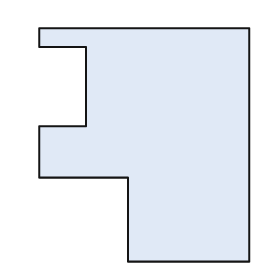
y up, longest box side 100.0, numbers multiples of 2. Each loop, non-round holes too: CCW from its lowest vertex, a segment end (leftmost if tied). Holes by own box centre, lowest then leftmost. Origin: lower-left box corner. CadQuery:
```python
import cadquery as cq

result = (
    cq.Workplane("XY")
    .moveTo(38.0, 0.0)
    .lineTo(90.0, 0.0)
    .lineTo(90.0, 100.0)
    .lineTo(0.0, 100.0)
    .lineTo(0.0, 92.0)
    .lineTo(20.0, 92.0)
    .lineTo(20.0, 58.0)
    .lineTo(0.0, 58.0)
    .lineTo(0.0, 36.0)
    .lineTo(38.0, 36.0)
    .close()
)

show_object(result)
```